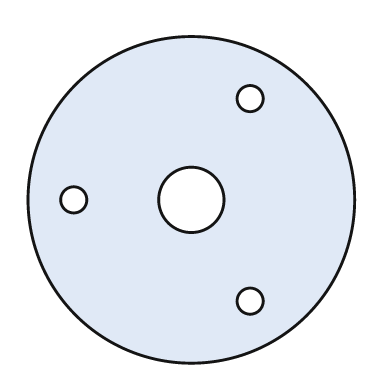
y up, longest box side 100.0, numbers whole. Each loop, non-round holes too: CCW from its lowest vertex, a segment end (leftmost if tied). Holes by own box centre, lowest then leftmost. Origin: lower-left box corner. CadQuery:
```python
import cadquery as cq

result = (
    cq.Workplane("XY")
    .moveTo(50.0, 50.0)
    .circle(50.0)
    .moveTo(68.0, 19.0)
    .circle(4.0)
    .moveTo(14.0, 50.0)
    .circle(4.0)
    .moveTo(50.0, 50.0)
    .circle(10.0)
    .moveTo(68.0, 81.0)
    .circle(4.0)
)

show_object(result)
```